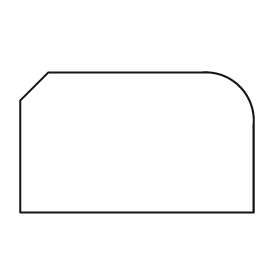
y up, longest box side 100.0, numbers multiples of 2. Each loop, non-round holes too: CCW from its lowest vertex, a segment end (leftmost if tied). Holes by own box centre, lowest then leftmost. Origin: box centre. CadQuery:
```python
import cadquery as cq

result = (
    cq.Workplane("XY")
    .moveTo(-50.0, -30.0)
    .lineTo(50.0, -30.0)
    .lineTo(50.0, 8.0)
    .threePointArc((44.0, 24.0), (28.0, 30.0))
    .lineTo(-38.0, 30.0)
    .lineTo(-50.0, 18.0)
    .close()
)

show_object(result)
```